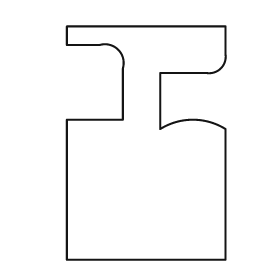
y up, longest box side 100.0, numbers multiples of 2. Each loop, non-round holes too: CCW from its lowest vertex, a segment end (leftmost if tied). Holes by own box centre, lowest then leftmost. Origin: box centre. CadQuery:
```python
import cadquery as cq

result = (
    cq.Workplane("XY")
    .moveTo(-34.0, -50.0)
    .lineTo(34.0, -50.0)
    .lineTo(34.0, 6.0)
    .threePointArc((20.0, 10.0), (6.0, 6.0))
    .lineTo(6.0, 30.0)
    .lineTo(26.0, 30.0)
    .threePointArc((32.0, 32.0), (34.0, 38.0))
    .lineTo(34.0, 50.0)
    .lineTo(-34.0, 50.0)
    .lineTo(-34.0, 42.0)
    .lineTo(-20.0, 42.0)
    .threePointArc((-12.0, 40.0), (-10.0, 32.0))
    .lineTo(-10.0, 10.0)
    .lineTo(-34.0, 10.0)
    .close()
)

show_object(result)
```